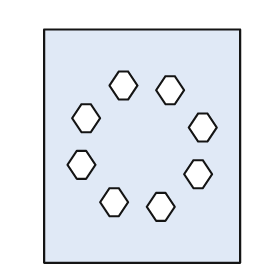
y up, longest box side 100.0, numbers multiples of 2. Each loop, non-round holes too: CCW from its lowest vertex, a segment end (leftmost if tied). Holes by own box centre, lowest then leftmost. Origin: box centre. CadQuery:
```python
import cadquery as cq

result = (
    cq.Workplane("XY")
    .moveTo(-42.0, -50.0)
    .lineTo(42.0, -50.0)
    .lineTo(42.0, 50.0)
    .lineTo(-42.0, 50.0)
    .close()
    .moveTo(6.0, -32.0)
    .lineTo(10.0, -32.0)
    .lineTo(14.0, -26.0)
    .lineTo(10.0, -20.0)
    .lineTo(6.0, -20.0)
    .lineTo(2.0, -26.0)
    .close()
    .moveTo(-14.0, -30.0)
    .lineTo(-10.0, -30.0)
    .lineTo(-6.0, -24.0)
    .lineTo(-10.0, -18.0)
    .lineTo(-14.0, -18.0)
    .lineTo(-18.0, -24.0)
    .close()
    .moveTo(22.0, -18.0)
    .lineTo(26.0, -18.0)
    .lineTo(30.0, -12.0)
    .lineTo(26.0, -6.0)
    .lineTo(22.0, -6.0)
    .lineTo(18.0, -12.0)
    .close()
    .moveTo(-28.0, -14.0)
    .lineTo(-24.0, -14.0)
    .lineTo(-20.0, -8.0)
    .lineTo(-24.0, -2.0)
    .lineTo(-28.0, -2.0)
    .lineTo(-32.0, -8.0)
    .close()
    .moveTo(24.0, 2.0)
    .lineTo(28.0, 2.0)
    .lineTo(32.0, 8.0)
    .lineTo(28.0, 14.0)
    .lineTo(24.0, 14.0)
    .lineTo(20.0, 8.0)
    .close()
    .moveTo(-26.0, 6.0)
    .lineTo(-22.0, 6.0)
    .lineTo(-18.0, 12.0)
    .lineTo(-22.0, 18.0)
    .lineTo(-26.0, 18.0)
    .lineTo(-30.0, 12.0)
    .close()
    .moveTo(10.0, 18.0)
    .lineTo(14.0, 18.0)
    .lineTo(18.0, 24.0)
    .lineTo(14.0, 30.0)
    .lineTo(10.0, 30.0)
    .lineTo(6.0, 24.0)
    .close()
    .moveTo(-10.0, 20.0)
    .lineTo(-6.0, 20.0)
    .lineTo(-2.0, 26.0)
    .lineTo(-6.0, 32.0)
    .lineTo(-10.0, 32.0)
    .lineTo(-14.0, 26.0)
    .close()
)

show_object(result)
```